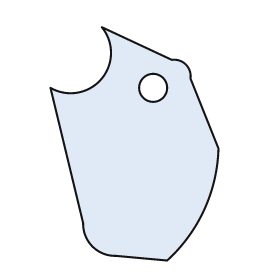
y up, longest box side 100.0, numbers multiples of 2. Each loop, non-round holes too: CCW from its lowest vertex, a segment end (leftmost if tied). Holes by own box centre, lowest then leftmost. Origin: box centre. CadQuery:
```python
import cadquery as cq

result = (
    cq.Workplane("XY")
    .moveTo(14.0, -50.0)
    .threePointArc((30.0, -28.0), (36.0, -2.0))
    .lineTo(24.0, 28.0)
    .threePointArc((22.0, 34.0), (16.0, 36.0))
    .lineTo(-14.0, 50.0)
    .threePointArc((-14.0, 28.0), (-36.0, 24.0))
    .lineTo(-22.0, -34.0)
    .threePointArc((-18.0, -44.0), (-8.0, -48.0))
    .close()
    .moveTo(8.0, 24.0)
    .circle(6.0)
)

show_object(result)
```